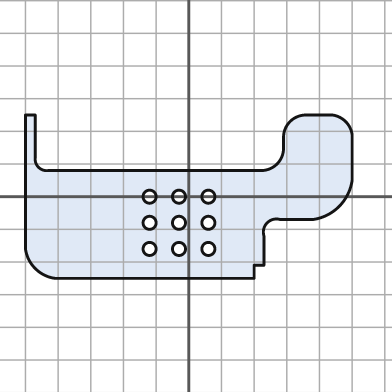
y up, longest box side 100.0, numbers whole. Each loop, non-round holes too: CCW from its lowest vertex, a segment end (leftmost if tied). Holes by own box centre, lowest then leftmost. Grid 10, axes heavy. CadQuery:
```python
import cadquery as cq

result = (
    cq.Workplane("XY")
    .moveTo(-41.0, -25.0)
    .lineTo(20.0, -25.0)
    .lineTo(20.0, -21.0)
    .lineTo(23.0, -21.0)
    .lineTo(23.0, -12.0)
    .threePointArc((24.0, -8.0), (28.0, -7.0))
    .lineTo(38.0, -7.0)
    .threePointArc((46.0, -3.0), (50.0, 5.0))
    .lineTo(50.0, 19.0)
    .threePointArc((48.0, 23.0), (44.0, 25.0))
    .lineTo(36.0, 25.0)
    .threePointArc((31.0, 23.0), (29.0, 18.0))
    .lineTo(29.0, 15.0)
    .threePointArc((27.0, 10.0), (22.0, 8.0))
    .lineTo(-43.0, 8.0)
    .threePointArc((-46.0, 9.0), (-47.0, 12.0))
    .lineTo(-47.0, 25.0)
    .lineTo(-50.0, 25.0)
    .lineTo(-50.0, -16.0)
    .threePointArc((-47.0, -22.0), (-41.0, -25.0))
    .close()
    .moveTo(-12.0, -16.0)
    .circle(2.0)
    .moveTo(-3.0, -16.0)
    .circle(2.0)
    .moveTo(6.0, -16.0)
    .circle(2.0)
    .moveTo(-12.0, -8.0)
    .circle(2.0)
    .moveTo(-3.0, -8.0)
    .circle(2.0)
    .moveTo(6.0, -8.0)
    .circle(2.0)
    .moveTo(-12.0, 0.0)
    .circle(2.0)
    .moveTo(-3.0, 0.0)
    .circle(2.0)
    .moveTo(6.0, 0.0)
    .circle(2.0)
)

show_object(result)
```